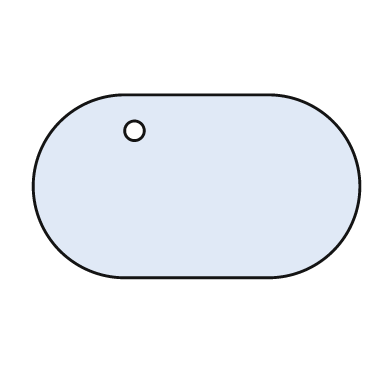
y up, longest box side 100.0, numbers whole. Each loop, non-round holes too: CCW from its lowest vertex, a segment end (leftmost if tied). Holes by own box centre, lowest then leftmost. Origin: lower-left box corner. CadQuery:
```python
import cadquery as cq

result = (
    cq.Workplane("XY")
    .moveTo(28.0, 0.0)
    .lineTo(72.0, 0.0)
    .threePointArc((100.0, 28.0), (72.0, 56.0))
    .lineTo(28.0, 56.0)
    .threePointArc((0.0, 28.0), (28.0, 0.0))
    .close()
    .moveTo(31.0, 45.0)
    .circle(3.0)
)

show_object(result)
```